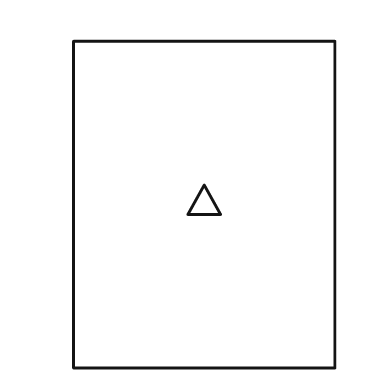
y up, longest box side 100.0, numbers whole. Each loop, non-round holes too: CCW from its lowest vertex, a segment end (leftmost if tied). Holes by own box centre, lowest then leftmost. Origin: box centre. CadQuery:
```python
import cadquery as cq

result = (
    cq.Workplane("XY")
    .moveTo(-40.0, -50.0)
    .lineTo(40.0, -50.0)
    .lineTo(40.0, 50.0)
    .lineTo(-40.0, 50.0)
    .close()
    .moveTo(-5.0, -3.0)
    .lineTo(5.0, -3.0)
    .lineTo(0.0, 6.0)
    .close()
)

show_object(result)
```